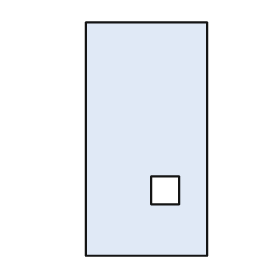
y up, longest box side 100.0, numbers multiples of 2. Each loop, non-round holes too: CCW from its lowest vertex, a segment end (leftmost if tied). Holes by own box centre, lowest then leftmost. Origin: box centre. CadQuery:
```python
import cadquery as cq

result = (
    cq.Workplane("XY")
    .moveTo(-26.0, -50.0)
    .lineTo(26.0, -50.0)
    .lineTo(26.0, 50.0)
    .lineTo(-26.0, 50.0)
    .close()
    .moveTo(2.0, -28.0)
    .lineTo(14.0, -28.0)
    .lineTo(14.0, -16.0)
    .lineTo(2.0, -16.0)
    .close()
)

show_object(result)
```